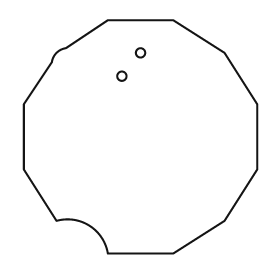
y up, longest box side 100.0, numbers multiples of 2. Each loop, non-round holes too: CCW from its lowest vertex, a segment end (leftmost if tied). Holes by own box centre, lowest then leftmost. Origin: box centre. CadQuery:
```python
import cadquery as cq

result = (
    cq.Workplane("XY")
    .moveTo(-14.0, -50.0)
    .lineTo(14.0, -50.0)
    .lineTo(36.0, -36.0)
    .lineTo(50.0, -14.0)
    .lineTo(50.0, 14.0)
    .lineTo(36.0, 36.0)
    .lineTo(14.0, 50.0)
    .lineTo(-14.0, 50.0)
    .lineTo(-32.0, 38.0)
    .threePointArc((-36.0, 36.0), (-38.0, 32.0))
    .lineTo(-50.0, 14.0)
    .lineTo(-50.0, -14.0)
    .lineTo(-36.0, -36.0)
    .threePointArc((-22.0, -38.0), (-14.0, -50.0))
    .close()
    .moveTo(-8.0, 26.0)
    .circle(2.0)
    .moveTo(0.0, 36.0)
    .circle(2.0)
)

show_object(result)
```